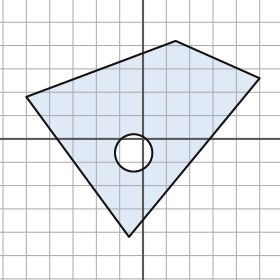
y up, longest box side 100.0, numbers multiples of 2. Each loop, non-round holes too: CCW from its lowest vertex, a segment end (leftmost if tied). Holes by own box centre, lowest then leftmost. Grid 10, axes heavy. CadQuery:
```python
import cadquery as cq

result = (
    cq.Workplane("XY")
    .moveTo(-6.0, -42.0)
    .lineTo(50.0, 26.0)
    .lineTo(14.0, 42.0)
    .lineTo(-50.0, 18.0)
    .close()
    .moveTo(-4.0, -6.0)
    .circle(8.0)
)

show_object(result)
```